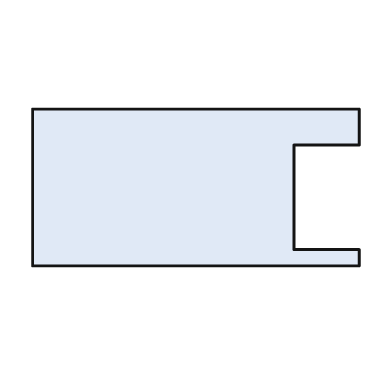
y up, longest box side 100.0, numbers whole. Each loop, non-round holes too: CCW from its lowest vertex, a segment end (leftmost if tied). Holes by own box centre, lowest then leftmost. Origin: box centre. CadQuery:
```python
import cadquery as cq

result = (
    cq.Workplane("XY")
    .moveTo(-50.0, -24.0)
    .lineTo(50.0, -24.0)
    .lineTo(50.0, -19.0)
    .lineTo(30.0, -19.0)
    .lineTo(30.0, 13.0)
    .lineTo(50.0, 13.0)
    .lineTo(50.0, 24.0)
    .lineTo(-50.0, 24.0)
    .close()
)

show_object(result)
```